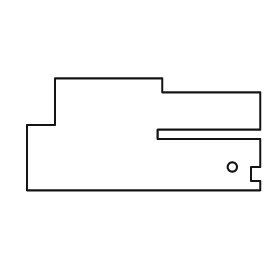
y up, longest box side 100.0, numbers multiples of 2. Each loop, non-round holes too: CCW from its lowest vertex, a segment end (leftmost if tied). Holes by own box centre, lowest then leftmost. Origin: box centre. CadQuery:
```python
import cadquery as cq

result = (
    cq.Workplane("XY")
    .moveTo(-50.0, -24.0)
    .lineTo(50.0, -24.0)
    .lineTo(50.0, -20.0)
    .lineTo(46.0, -20.0)
    .lineTo(46.0, -14.0)
    .lineTo(50.0, -14.0)
    .lineTo(50.0, -2.0)
    .lineTo(6.0, -2.0)
    .lineTo(6.0, 2.0)
    .lineTo(50.0, 2.0)
    .lineTo(50.0, 18.0)
    .lineTo(8.0, 18.0)
    .lineTo(8.0, 24.0)
    .lineTo(-38.0, 24.0)
    .lineTo(-38.0, 4.0)
    .lineTo(-50.0, 4.0)
    .close()
    .moveTo(38.0, -14.0)
    .circle(2.0)
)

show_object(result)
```